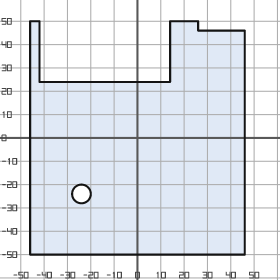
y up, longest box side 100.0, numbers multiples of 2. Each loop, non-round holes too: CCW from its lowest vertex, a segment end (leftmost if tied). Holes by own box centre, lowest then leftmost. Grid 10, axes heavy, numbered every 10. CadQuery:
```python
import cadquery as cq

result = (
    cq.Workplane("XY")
    .moveTo(-46.0, -50.0)
    .lineTo(46.0, -50.0)
    .lineTo(46.0, 46.0)
    .lineTo(26.0, 46.0)
    .lineTo(26.0, 50.0)
    .lineTo(14.0, 50.0)
    .lineTo(14.0, 24.0)
    .lineTo(-42.0, 24.0)
    .lineTo(-42.0, 50.0)
    .lineTo(-46.0, 50.0)
    .close()
    .moveTo(-24.0, -24.0)
    .circle(4.0)
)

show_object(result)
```